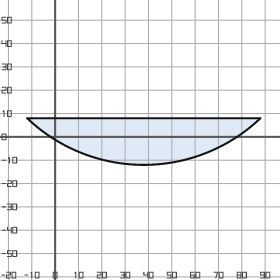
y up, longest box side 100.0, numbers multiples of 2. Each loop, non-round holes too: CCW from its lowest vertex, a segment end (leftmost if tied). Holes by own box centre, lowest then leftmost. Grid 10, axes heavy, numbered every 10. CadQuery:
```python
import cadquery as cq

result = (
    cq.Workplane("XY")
    .moveTo(-12.0, 8.0)
    .threePointArc((38.0, -12.0), (88.0, 8.0))
    .close()
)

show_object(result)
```